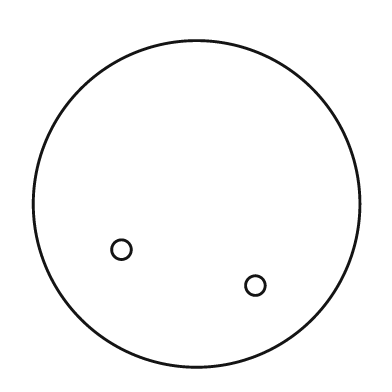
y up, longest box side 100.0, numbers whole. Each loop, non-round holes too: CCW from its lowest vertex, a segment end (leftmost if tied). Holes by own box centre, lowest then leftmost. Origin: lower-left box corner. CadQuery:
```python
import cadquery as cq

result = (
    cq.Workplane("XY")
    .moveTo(50.0, 50.0)
    .circle(50.0)
    .moveTo(68.0, 25.0)
    .circle(3.0)
    .moveTo(27.0, 36.0)
    .circle(3.0)
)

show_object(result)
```